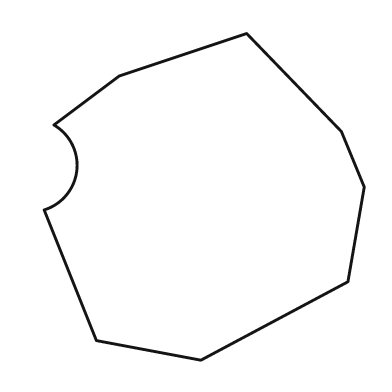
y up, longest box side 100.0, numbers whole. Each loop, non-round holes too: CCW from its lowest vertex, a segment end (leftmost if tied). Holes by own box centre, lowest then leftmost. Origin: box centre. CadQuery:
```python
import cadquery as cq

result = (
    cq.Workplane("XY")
    .moveTo(-1.0, -50.0)
    .lineTo(44.0, -26.0)
    .lineTo(49.0, 3.0)
    .lineTo(42.0, 20.0)
    .lineTo(13.0, 50.0)
    .lineTo(-26.0, 37.0)
    .lineTo(-46.0, 22.0)
    .threePointArc((-39.0, 8.0), (-49.0, -4.0))
    .lineTo(-33.0, -44.0)
    .close()
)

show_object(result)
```